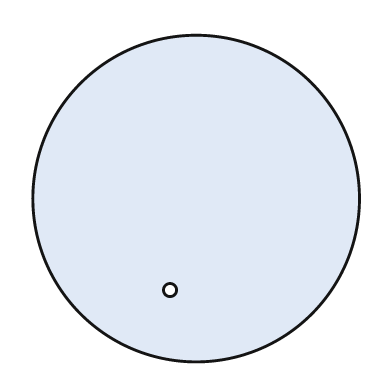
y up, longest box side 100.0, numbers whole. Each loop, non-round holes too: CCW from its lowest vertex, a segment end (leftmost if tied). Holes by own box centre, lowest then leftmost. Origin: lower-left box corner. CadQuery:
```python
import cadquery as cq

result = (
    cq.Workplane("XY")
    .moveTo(50.0, 50.0)
    .circle(50.0)
    .moveTo(42.0, 22.0)
    .circle(2.0)
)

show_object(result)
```